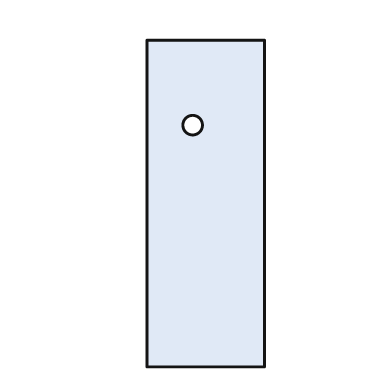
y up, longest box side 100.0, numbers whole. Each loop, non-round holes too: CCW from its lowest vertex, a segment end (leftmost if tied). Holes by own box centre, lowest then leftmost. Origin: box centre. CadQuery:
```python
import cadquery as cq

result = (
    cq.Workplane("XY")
    .moveTo(-18.0, -50.0)
    .lineTo(18.0, -50.0)
    .lineTo(18.0, 50.0)
    .lineTo(-18.0, 50.0)
    .close()
    .moveTo(-4.0, 24.0)
    .circle(3.0)
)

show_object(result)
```